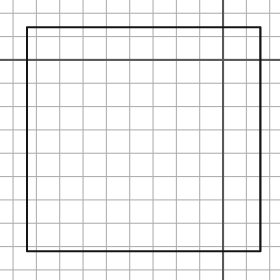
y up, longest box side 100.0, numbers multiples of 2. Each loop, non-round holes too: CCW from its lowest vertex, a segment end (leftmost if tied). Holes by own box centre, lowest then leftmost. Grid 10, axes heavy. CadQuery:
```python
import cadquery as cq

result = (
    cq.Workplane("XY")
    .moveTo(-84.0, -82.0)
    .lineTo(16.0, -82.0)
    .lineTo(16.0, 14.0)
    .lineTo(-84.0, 14.0)
    .close()
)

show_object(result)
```